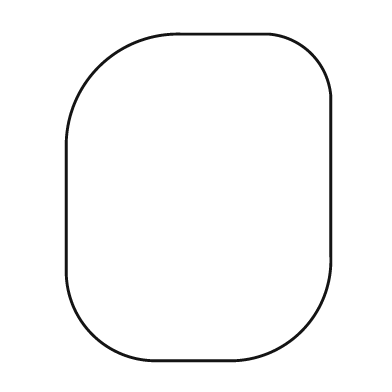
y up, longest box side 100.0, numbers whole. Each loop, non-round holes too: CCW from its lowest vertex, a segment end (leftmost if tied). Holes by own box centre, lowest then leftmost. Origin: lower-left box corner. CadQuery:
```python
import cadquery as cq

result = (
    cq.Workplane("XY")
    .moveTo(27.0, 0.0)
    .lineTo(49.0, 0.0)
    .threePointArc((72.0, 9.0), (81.0, 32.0))
    .lineTo(81.0, 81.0)
    .threePointArc((75.0, 94.0), (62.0, 100.0))
    .lineTo(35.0, 100.0)
    .threePointArc((10.0, 90.0), (0.0, 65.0))
    .lineTo(0.0, 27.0)
    .threePointArc((8.0, 8.0), (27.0, 0.0))
    .close()
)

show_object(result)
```